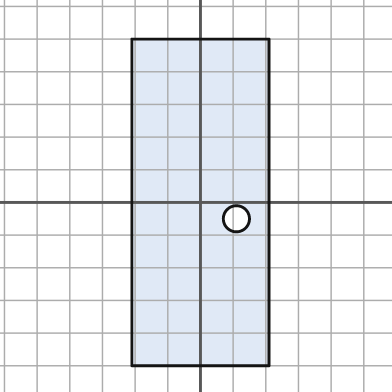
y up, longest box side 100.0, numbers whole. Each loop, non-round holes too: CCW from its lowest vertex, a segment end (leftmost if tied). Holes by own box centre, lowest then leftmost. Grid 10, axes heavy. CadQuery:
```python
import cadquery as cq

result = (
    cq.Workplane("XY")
    .moveTo(-21.0, -50.0)
    .lineTo(21.0, -50.0)
    .lineTo(21.0, 50.0)
    .lineTo(-21.0, 50.0)
    .close()
    .moveTo(11.0, -5.0)
    .circle(4.0)
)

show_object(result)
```